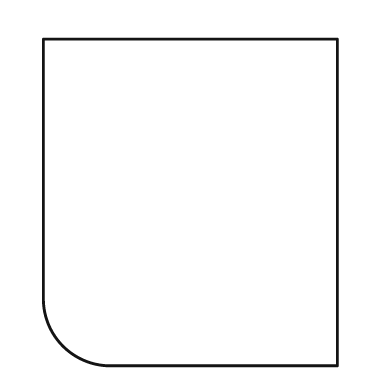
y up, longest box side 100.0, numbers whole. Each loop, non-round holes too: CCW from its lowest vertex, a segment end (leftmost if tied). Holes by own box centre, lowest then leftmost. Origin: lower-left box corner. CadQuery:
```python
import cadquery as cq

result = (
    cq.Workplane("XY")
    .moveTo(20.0, 0.0)
    .lineTo(90.0, 0.0)
    .lineTo(90.0, 100.0)
    .lineTo(0.0, 100.0)
    .lineTo(0.0, 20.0)
    .threePointArc((6.0, 6.0), (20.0, 0.0))
    .close()
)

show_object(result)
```